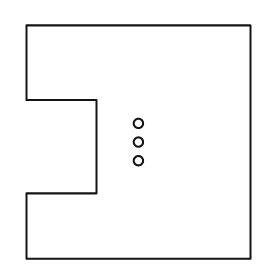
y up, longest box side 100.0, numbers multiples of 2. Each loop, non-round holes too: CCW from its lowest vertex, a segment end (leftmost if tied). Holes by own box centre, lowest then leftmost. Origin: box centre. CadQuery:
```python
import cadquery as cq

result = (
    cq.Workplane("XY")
    .moveTo(-48.0, -50.0)
    .lineTo(48.0, -50.0)
    .lineTo(48.0, 50.0)
    .lineTo(-48.0, 50.0)
    .lineTo(-48.0, 18.0)
    .lineTo(-18.0, 18.0)
    .lineTo(-18.0, -22.0)
    .lineTo(-48.0, -22.0)
    .close()
    .moveTo(0.0, -8.0)
    .circle(2.0)
    .moveTo(0.0, 0.0)
    .circle(2.0)
    .moveTo(0.0, 8.0)
    .circle(2.0)
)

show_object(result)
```